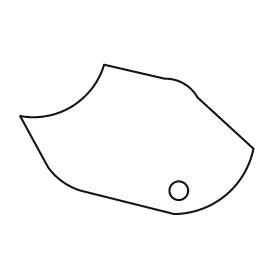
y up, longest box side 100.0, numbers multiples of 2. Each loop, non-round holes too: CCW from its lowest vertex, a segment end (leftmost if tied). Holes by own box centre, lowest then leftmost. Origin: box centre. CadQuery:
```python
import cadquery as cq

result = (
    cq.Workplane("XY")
    .moveTo(16.0, -32.0)
    .threePointArc((38.0, -24.0), (50.0, -4.0))
    .lineTo(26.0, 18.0)
    .threePointArc((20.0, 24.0), (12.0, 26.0))
    .lineTo(-14.0, 32.0)
    .threePointArc((-28.0, 14.0), (-50.0, 10.0))
    .lineTo(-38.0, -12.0)
    .threePointArc((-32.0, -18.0), (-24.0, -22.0))
    .close()
    .moveTo(18.0, -22.0)
    .circle(4.0)
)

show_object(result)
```